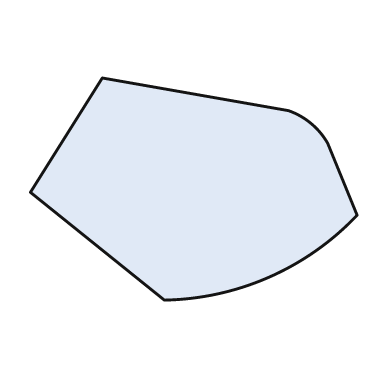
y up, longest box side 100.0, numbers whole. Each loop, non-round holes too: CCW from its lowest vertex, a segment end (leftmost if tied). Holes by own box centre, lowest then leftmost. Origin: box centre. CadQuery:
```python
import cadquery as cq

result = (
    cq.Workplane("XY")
    .moveTo(-9.0, -34.0)
    .threePointArc((23.0, -27.0), (50.0, -8.0))
    .lineTo(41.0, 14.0)
    .threePointArc((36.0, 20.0), (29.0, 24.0))
    .lineTo(-28.0, 34.0)
    .lineTo(-50.0, -1.0)
    .close()
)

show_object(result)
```